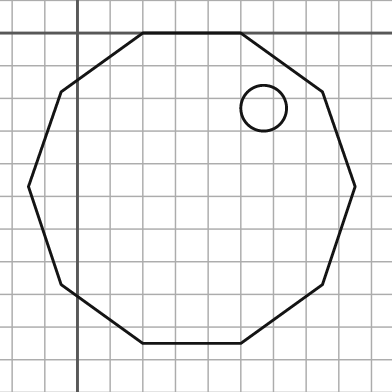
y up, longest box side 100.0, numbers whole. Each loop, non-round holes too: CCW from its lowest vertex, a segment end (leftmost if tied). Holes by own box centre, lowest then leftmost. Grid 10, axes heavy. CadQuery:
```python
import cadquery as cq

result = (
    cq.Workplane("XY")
    .moveTo(20.0, -95.0)
    .lineTo(50.0, -95.0)
    .lineTo(75.0, -77.0)
    .lineTo(85.0, -47.0)
    .lineTo(75.0, -18.0)
    .lineTo(50.0, 0.0)
    .lineTo(20.0, 0.0)
    .lineTo(-5.0, -18.0)
    .lineTo(-15.0, -47.0)
    .lineTo(-5.0, -77.0)
    .close()
    .moveTo(57.0, -23.0)
    .circle(7.0)
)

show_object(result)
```